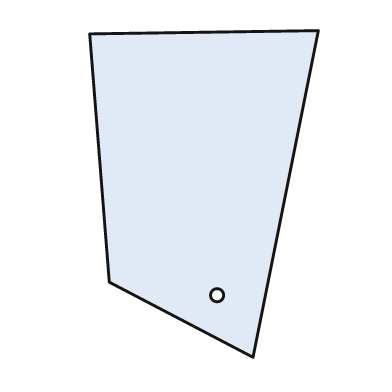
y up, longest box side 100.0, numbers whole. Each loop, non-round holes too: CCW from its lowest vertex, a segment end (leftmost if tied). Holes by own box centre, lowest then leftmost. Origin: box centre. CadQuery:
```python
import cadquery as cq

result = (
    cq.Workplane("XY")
    .moveTo(15.0, -50.0)
    .lineTo(35.0, 50.0)
    .lineTo(-35.0, 49.0)
    .lineTo(-29.0, -27.0)
    .close()
    .moveTo(4.0, -31.0)
    .circle(2.0)
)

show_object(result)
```